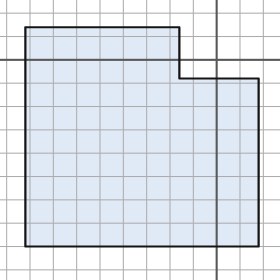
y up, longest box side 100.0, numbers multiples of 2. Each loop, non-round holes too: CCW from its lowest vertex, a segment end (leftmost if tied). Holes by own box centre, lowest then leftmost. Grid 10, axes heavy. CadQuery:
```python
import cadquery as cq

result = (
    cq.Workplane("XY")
    .moveTo(-82.0, -80.0)
    .lineTo(18.0, -80.0)
    .lineTo(18.0, -8.0)
    .lineTo(-16.0, -8.0)
    .lineTo(-16.0, 14.0)
    .lineTo(-82.0, 14.0)
    .close()
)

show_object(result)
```